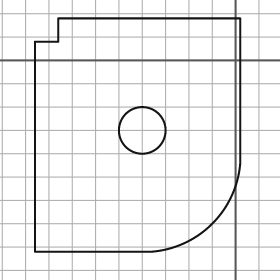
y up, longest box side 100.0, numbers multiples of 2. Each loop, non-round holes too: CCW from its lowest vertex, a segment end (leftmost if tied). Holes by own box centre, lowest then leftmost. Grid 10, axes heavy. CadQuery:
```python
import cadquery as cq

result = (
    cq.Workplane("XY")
    .moveTo(-86.0, -82.0)
    .lineTo(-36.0, -82.0)
    .threePointArc((-10.0, -70.0), (2.0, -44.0))
    .lineTo(2.0, 18.0)
    .lineTo(-76.0, 18.0)
    .lineTo(-76.0, 8.0)
    .lineTo(-86.0, 8.0)
    .close()
    .moveTo(-40.0, -30.0)
    .circle(10.0)
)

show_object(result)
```